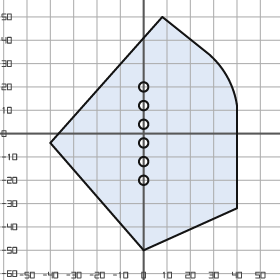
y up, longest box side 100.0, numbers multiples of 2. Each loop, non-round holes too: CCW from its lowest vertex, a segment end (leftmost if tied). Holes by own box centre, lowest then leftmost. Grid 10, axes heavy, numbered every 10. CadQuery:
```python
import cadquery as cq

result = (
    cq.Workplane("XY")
    .moveTo(0.0, -50.0)
    .lineTo(40.0, -32.0)
    .lineTo(40.0, 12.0)
    .threePointArc((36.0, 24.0), (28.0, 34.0))
    .lineTo(8.0, 50.0)
    .lineTo(-40.0, -4.0)
    .close()
    .moveTo(0.0, -20.0)
    .circle(2.0)
    .moveTo(0.0, -12.0)
    .circle(2.0)
    .moveTo(0.0, -4.0)
    .circle(2.0)
    .moveTo(0.0, 4.0)
    .circle(2.0)
    .moveTo(0.0, 12.0)
    .circle(2.0)
    .moveTo(0.0, 20.0)
    .circle(2.0)
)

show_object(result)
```